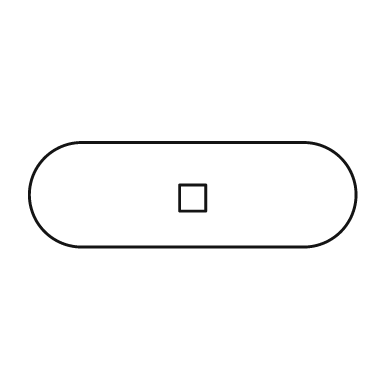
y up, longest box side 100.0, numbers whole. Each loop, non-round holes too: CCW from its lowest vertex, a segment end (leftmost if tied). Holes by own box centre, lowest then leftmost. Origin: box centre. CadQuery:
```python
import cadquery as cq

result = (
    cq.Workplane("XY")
    .moveTo(-34.0, -16.0)
    .lineTo(34.0, -16.0)
    .threePointArc((50.0, 0.0), (34.0, 16.0))
    .lineTo(-34.0, 16.0)
    .threePointArc((-50.0, 0.0), (-34.0, -16.0))
    .close()
    .moveTo(-4.0, -5.0)
    .lineTo(4.0, -5.0)
    .lineTo(4.0, 3.0)
    .lineTo(-4.0, 3.0)
    .close()
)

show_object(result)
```